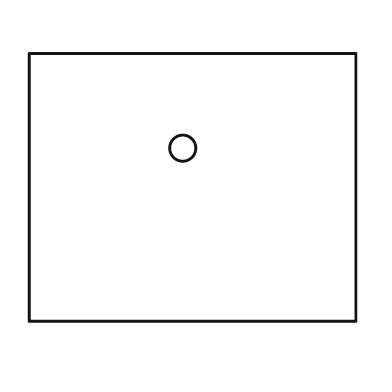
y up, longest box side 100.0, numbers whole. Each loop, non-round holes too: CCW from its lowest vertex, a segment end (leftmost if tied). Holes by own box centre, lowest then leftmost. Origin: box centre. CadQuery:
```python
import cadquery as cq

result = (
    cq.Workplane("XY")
    .moveTo(-50.0, -41.0)
    .lineTo(50.0, -41.0)
    .lineTo(50.0, 41.0)
    .lineTo(-50.0, 41.0)
    .close()
    .moveTo(-3.0, 12.0)
    .circle(4.0)
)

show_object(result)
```